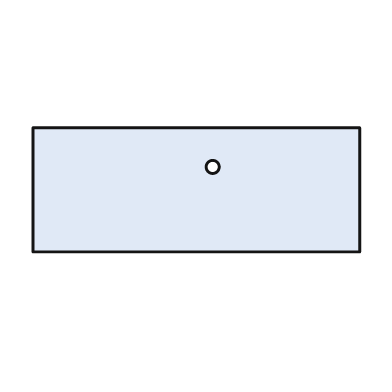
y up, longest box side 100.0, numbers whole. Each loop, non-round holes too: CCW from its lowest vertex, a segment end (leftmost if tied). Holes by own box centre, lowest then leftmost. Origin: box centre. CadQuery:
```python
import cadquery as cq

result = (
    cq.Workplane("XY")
    .moveTo(-50.0, -19.0)
    .lineTo(50.0, -19.0)
    .lineTo(50.0, 19.0)
    .lineTo(-50.0, 19.0)
    .close()
    .moveTo(5.0, 7.0)
    .circle(2.0)
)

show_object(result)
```